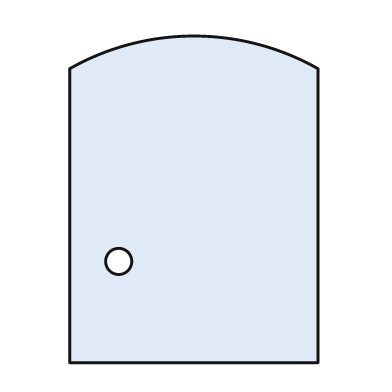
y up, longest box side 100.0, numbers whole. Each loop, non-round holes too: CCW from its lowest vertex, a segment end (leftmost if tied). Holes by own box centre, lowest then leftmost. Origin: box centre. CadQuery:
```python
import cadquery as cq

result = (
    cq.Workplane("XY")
    .moveTo(-38.0, -50.0)
    .lineTo(38.0, -50.0)
    .lineTo(38.0, 40.0)
    .threePointArc((0.0, 50.0), (-38.0, 40.0))
    .close()
    .moveTo(-23.0, -19.0)
    .circle(4.0)
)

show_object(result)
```